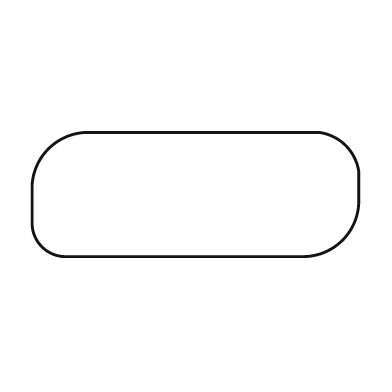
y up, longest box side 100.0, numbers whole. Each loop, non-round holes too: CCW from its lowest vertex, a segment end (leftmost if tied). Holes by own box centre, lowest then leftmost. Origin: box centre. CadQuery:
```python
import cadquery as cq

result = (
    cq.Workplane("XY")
    .moveTo(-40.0, -19.0)
    .lineTo(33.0, -19.0)
    .threePointArc((45.0, -14.0), (50.0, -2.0))
    .lineTo(50.0, 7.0)
    .threePointArc((46.0, 15.0), (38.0, 19.0))
    .lineTo(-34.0, 19.0)
    .threePointArc((-45.0, 14.0), (-50.0, 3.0))
    .lineTo(-50.0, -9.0)
    .threePointArc((-47.0, -16.0), (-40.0, -19.0))
    .close()
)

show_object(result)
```